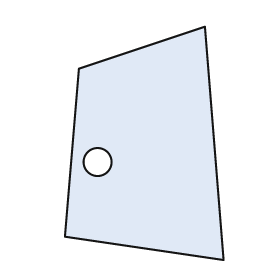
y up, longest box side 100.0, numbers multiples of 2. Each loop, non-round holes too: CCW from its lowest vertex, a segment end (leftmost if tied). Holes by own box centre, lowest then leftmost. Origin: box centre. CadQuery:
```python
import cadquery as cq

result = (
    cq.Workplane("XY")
    .moveTo(34.0, -50.0)
    .lineTo(26.0, 50.0)
    .lineTo(-28.0, 32.0)
    .lineTo(-34.0, -40.0)
    .close()
    .moveTo(-20.0, -8.0)
    .circle(6.0)
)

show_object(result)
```